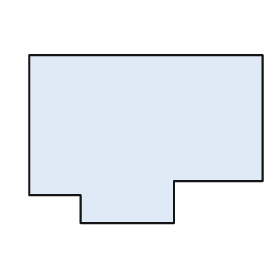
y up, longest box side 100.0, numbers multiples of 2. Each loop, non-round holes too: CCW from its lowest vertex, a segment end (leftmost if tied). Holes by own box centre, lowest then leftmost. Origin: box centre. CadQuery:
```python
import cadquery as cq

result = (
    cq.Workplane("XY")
    .moveTo(-28.0, -36.0)
    .lineTo(12.0, -36.0)
    .lineTo(12.0, -18.0)
    .lineTo(50.0, -18.0)
    .lineTo(50.0, 36.0)
    .lineTo(-50.0, 36.0)
    .lineTo(-50.0, -24.0)
    .lineTo(-28.0, -24.0)
    .close()
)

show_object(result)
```